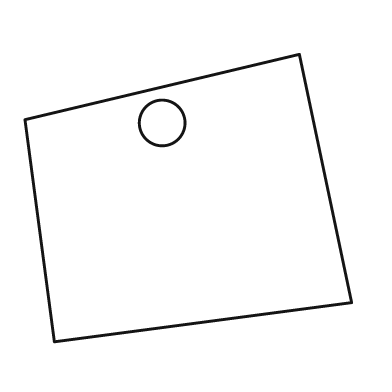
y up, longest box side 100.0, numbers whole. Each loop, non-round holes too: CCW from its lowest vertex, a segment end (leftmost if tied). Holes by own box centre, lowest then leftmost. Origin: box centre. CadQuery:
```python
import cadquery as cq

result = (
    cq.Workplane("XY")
    .moveTo(-41.0, -44.0)
    .lineTo(50.0, -32.0)
    .lineTo(34.0, 44.0)
    .lineTo(-50.0, 24.0)
    .close()
    .moveTo(-8.0, 23.0)
    .circle(7.0)
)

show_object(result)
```